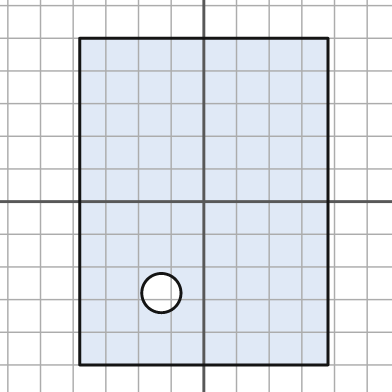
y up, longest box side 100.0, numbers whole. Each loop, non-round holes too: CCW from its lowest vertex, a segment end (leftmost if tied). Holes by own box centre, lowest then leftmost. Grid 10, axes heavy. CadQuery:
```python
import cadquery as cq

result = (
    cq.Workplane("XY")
    .moveTo(-38.0, -50.0)
    .lineTo(38.0, -50.0)
    .lineTo(38.0, 50.0)
    .lineTo(-38.0, 50.0)
    .close()
    .moveTo(-13.0, -28.0)
    .circle(6.0)
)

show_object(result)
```